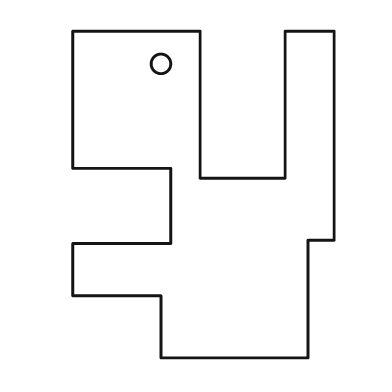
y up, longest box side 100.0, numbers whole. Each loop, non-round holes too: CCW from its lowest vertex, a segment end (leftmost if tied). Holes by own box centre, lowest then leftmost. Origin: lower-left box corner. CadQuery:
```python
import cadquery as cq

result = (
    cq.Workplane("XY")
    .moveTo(27.0, 0.0)
    .lineTo(72.0, 0.0)
    .lineTo(72.0, 36.0)
    .lineTo(80.0, 36.0)
    .lineTo(80.0, 100.0)
    .lineTo(65.0, 100.0)
    .lineTo(65.0, 55.0)
    .lineTo(39.0, 55.0)
    .lineTo(39.0, 100.0)
    .lineTo(0.0, 100.0)
    .lineTo(0.0, 58.0)
    .lineTo(30.0, 58.0)
    .lineTo(30.0, 35.0)
    .lineTo(0.0, 35.0)
    .lineTo(0.0, 19.0)
    .lineTo(27.0, 19.0)
    .close()
    .moveTo(27.0, 90.0)
    .circle(3.0)
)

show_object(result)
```